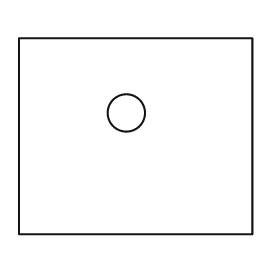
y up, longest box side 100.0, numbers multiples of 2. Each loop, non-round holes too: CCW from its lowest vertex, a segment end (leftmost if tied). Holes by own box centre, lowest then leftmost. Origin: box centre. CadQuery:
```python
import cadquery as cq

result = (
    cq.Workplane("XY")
    .moveTo(-50.0, -42.0)
    .lineTo(50.0, -42.0)
    .lineTo(50.0, 42.0)
    .lineTo(-50.0, 42.0)
    .close()
    .moveTo(-4.0, 10.0)
    .circle(8.0)
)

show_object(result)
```